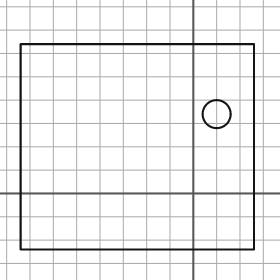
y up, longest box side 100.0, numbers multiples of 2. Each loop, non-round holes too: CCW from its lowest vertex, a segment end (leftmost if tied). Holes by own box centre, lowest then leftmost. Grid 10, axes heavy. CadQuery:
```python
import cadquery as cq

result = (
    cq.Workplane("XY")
    .moveTo(-74.0, -24.0)
    .lineTo(26.0, -24.0)
    .lineTo(26.0, 64.0)
    .lineTo(-74.0, 64.0)
    .close()
    .moveTo(10.0, 34.0)
    .circle(6.0)
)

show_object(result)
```